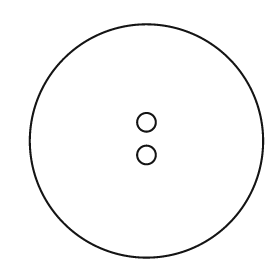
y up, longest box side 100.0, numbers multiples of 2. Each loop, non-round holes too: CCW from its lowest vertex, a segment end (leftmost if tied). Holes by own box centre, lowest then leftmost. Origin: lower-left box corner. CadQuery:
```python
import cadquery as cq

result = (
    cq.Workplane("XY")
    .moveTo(50.0, 50.0)
    .circle(50.0)
    .moveTo(50.0, 44.0)
    .circle(4.0)
    .moveTo(50.0, 58.0)
    .circle(4.0)
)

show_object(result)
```